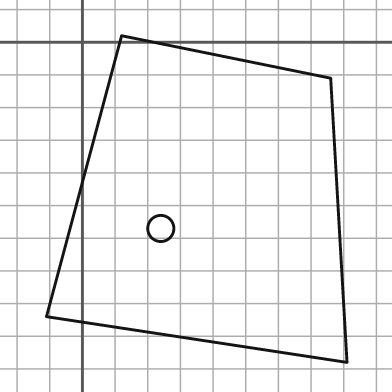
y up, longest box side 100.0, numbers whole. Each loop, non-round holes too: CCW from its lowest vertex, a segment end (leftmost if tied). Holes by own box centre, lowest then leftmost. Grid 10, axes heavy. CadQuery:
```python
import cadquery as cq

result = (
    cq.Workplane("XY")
    .moveTo(81.0, -98.0)
    .lineTo(76.0, -11.0)
    .lineTo(12.0, 2.0)
    .lineTo(-11.0, -84.0)
    .close()
    .moveTo(24.0, -57.0)
    .circle(4.0)
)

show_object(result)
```